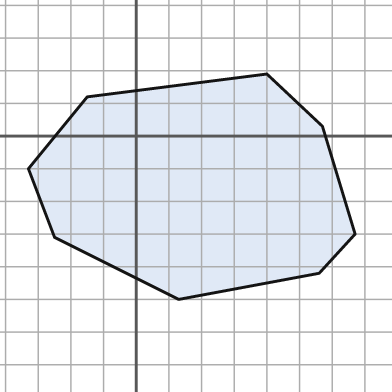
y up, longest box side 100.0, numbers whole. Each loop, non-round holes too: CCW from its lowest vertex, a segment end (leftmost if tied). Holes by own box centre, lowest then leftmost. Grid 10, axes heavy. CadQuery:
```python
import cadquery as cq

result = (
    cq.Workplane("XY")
    .moveTo(13.0, -50.0)
    .lineTo(56.0, -42.0)
    .lineTo(67.0, -30.0)
    .lineTo(57.0, 3.0)
    .lineTo(40.0, 19.0)
    .lineTo(-15.0, 12.0)
    .lineTo(-33.0, -10.0)
    .lineTo(-25.0, -31.0)
    .close()
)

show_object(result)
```